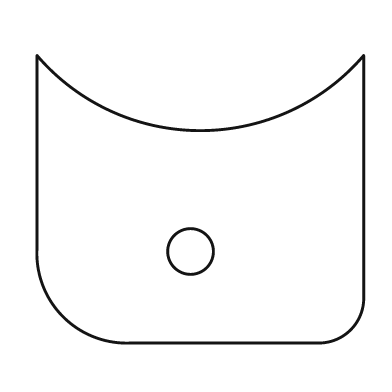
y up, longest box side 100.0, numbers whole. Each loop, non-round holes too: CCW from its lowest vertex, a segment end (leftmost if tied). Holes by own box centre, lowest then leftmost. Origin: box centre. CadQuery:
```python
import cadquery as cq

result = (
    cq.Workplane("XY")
    .moveTo(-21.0, -44.0)
    .lineTo(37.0, -44.0)
    .threePointArc((46.0, -40.0), (50.0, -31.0))
    .lineTo(50.0, 44.0)
    .threePointArc((0.0, 21.0), (-50.0, 44.0))
    .lineTo(-50.0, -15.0)
    .threePointArc((-42.0, -36.0), (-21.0, -44.0))
    .close()
    .moveTo(-3.0, -16.0)
    .circle(7.0)
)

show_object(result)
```